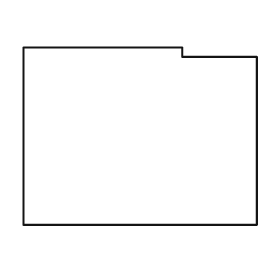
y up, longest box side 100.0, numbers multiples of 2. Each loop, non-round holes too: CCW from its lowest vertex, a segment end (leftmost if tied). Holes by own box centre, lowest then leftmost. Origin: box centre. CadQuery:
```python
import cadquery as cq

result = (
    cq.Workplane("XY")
    .moveTo(-50.0, -38.0)
    .lineTo(50.0, -38.0)
    .lineTo(50.0, 34.0)
    .lineTo(18.0, 34.0)
    .lineTo(18.0, 38.0)
    .lineTo(-50.0, 38.0)
    .close()
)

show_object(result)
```